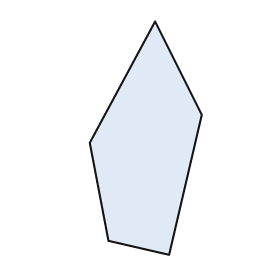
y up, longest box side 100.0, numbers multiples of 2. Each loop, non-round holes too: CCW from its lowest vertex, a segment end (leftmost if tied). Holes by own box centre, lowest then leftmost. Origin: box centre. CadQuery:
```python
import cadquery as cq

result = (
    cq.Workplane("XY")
    .moveTo(10.0, -50.0)
    .lineTo(24.0, 10.0)
    .lineTo(4.0, 50.0)
    .lineTo(-24.0, -2.0)
    .lineTo(-16.0, -44.0)
    .close()
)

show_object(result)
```